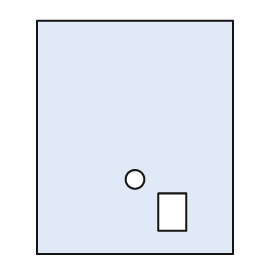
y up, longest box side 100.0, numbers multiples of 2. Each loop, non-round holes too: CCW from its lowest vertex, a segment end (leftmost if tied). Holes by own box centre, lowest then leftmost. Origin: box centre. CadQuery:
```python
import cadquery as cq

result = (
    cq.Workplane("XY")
    .moveTo(-42.0, -50.0)
    .lineTo(42.0, -50.0)
    .lineTo(42.0, 50.0)
    .lineTo(-42.0, 50.0)
    .close()
    .moveTo(10.0, -40.0)
    .lineTo(22.0, -40.0)
    .lineTo(22.0, -24.0)
    .lineTo(10.0, -24.0)
    .close()
    .moveTo(0.0, -18.0)
    .circle(4.0)
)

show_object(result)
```